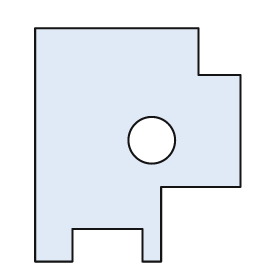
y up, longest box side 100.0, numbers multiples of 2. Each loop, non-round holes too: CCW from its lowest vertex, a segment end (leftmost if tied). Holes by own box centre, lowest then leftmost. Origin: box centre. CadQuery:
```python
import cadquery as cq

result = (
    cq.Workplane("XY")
    .moveTo(-44.0, -50.0)
    .lineTo(-28.0, -50.0)
    .lineTo(-28.0, -36.0)
    .lineTo(2.0, -36.0)
    .lineTo(2.0, -50.0)
    .lineTo(10.0, -50.0)
    .lineTo(10.0, -18.0)
    .lineTo(44.0, -18.0)
    .lineTo(44.0, 30.0)
    .lineTo(26.0, 30.0)
    .lineTo(26.0, 50.0)
    .lineTo(-44.0, 50.0)
    .close()
    .moveTo(6.0, 2.0)
    .circle(10.0)
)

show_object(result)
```